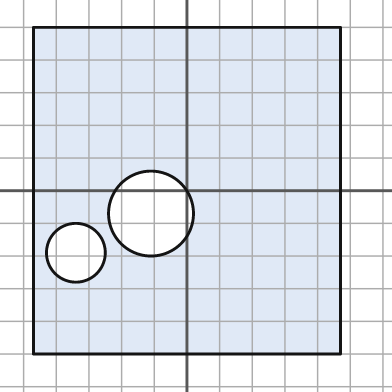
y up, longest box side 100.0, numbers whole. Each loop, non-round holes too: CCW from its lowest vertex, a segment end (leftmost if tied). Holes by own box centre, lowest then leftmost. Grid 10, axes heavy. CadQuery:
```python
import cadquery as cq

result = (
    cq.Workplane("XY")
    .moveTo(-47.0, -50.0)
    .lineTo(47.0, -50.0)
    .lineTo(47.0, 50.0)
    .lineTo(-47.0, 50.0)
    .close()
    .moveTo(-34.0, -19.0)
    .circle(9.0)
    .moveTo(-11.0, -7.0)
    .circle(13.0)
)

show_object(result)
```